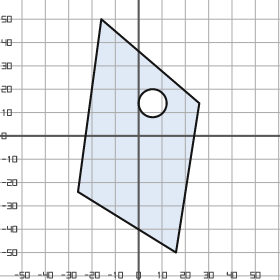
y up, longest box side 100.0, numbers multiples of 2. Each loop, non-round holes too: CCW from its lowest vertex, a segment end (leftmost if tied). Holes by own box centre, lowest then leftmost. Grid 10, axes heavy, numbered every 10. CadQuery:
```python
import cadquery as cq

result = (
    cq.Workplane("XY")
    .moveTo(16.0, -50.0)
    .lineTo(26.0, 14.0)
    .lineTo(-16.0, 50.0)
    .lineTo(-26.0, -24.0)
    .close()
    .moveTo(6.0, 14.0)
    .circle(6.0)
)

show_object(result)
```